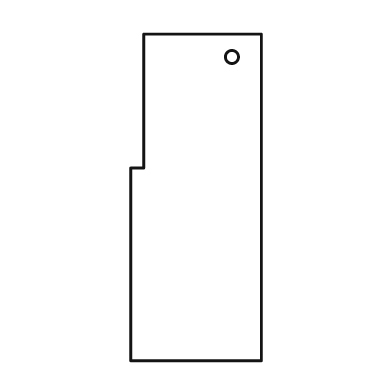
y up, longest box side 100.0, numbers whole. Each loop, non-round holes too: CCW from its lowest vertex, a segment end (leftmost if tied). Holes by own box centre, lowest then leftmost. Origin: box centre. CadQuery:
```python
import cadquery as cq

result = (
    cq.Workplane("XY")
    .moveTo(-20.0, -50.0)
    .lineTo(20.0, -50.0)
    .lineTo(20.0, 50.0)
    .lineTo(-16.0, 50.0)
    .lineTo(-16.0, 9.0)
    .lineTo(-20.0, 9.0)
    .close()
    .moveTo(11.0, 43.0)
    .circle(2.0)
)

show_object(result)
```